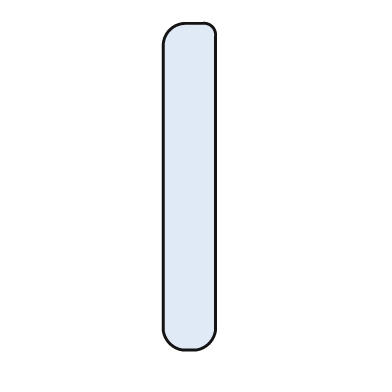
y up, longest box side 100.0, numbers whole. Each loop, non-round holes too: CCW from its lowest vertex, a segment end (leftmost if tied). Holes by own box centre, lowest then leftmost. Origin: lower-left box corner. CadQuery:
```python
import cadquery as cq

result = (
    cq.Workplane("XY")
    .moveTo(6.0, 0.0)
    .lineTo(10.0, 0.0)
    .threePointArc((14.0, 2.0), (16.0, 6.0))
    .lineTo(16.0, 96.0)
    .threePointArc((15.0, 99.0), (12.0, 100.0))
    .lineTo(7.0, 100.0)
    .threePointArc((2.0, 98.0), (0.0, 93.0))
    .lineTo(0.0, 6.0)
    .threePointArc((2.0, 2.0), (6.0, 0.0))
    .close()
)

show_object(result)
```